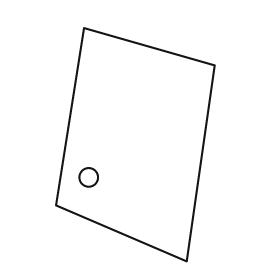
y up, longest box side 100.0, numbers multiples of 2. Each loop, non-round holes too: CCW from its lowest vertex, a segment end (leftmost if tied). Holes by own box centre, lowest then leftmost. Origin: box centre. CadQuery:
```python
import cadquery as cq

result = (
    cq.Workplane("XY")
    .moveTo(22.0, -50.0)
    .lineTo(34.0, 34.0)
    .lineTo(-22.0, 50.0)
    .lineTo(-34.0, -26.0)
    .close()
    .moveTo(-20.0, -14.0)
    .circle(4.0)
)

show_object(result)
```